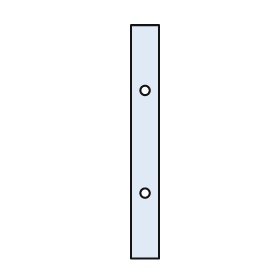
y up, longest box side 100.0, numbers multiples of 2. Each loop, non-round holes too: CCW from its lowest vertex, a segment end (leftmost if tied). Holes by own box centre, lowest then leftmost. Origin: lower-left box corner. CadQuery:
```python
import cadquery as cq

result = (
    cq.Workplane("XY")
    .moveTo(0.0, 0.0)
    .lineTo(12.0, 0.0)
    .lineTo(12.0, 100.0)
    .lineTo(0.0, 100.0)
    .close()
    .moveTo(6.0, 28.0)
    .circle(2.0)
    .moveTo(6.0, 72.0)
    .circle(2.0)
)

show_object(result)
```